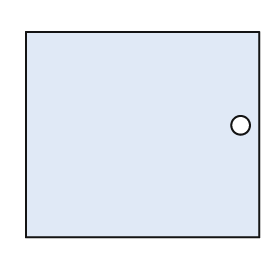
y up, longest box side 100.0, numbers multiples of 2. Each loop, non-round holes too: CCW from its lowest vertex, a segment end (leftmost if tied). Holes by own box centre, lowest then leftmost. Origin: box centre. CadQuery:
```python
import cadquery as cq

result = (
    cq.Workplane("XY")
    .moveTo(-50.0, -44.0)
    .lineTo(50.0, -44.0)
    .lineTo(50.0, 44.0)
    .lineTo(-50.0, 44.0)
    .close()
    .moveTo(42.0, 4.0)
    .circle(4.0)
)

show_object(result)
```